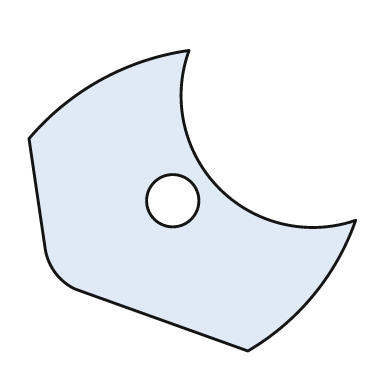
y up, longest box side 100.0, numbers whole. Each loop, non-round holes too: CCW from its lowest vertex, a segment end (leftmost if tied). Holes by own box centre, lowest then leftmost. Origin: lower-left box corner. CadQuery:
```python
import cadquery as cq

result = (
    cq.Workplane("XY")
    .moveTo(67.0, 0.0)
    .threePointArc((87.0, 17.0), (100.0, 40.0))
    .threePointArc((58.0, 50.0), (49.0, 92.0))
    .threePointArc((22.0, 83.0), (0.0, 65.0))
    .lineTo(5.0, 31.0)
    .threePointArc((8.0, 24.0), (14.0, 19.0))
    .close()
    .moveTo(44.0, 46.0)
    .circle(8.0)
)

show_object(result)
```